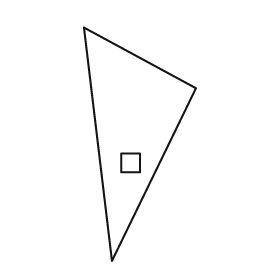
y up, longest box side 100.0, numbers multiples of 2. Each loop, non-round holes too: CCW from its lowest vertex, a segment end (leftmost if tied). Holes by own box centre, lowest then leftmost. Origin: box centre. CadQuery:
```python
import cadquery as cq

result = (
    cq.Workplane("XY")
    .moveTo(-12.0, -50.0)
    .lineTo(24.0, 24.0)
    .lineTo(-24.0, 50.0)
    .close()
    .moveTo(-8.0, -12.0)
    .lineTo(0.0, -12.0)
    .lineTo(0.0, -4.0)
    .lineTo(-8.0, -4.0)
    .close()
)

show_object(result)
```